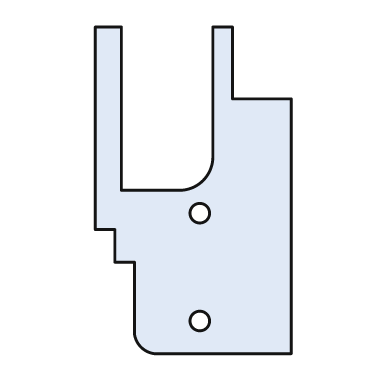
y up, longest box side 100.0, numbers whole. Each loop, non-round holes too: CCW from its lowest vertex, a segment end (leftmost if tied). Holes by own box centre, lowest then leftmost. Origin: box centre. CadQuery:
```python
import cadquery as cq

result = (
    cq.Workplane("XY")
    .moveTo(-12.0, -50.0)
    .lineTo(30.0, -50.0)
    .lineTo(30.0, 28.0)
    .lineTo(12.0, 28.0)
    .lineTo(12.0, 50.0)
    .lineTo(6.0, 50.0)
    .lineTo(6.0, 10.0)
    .threePointArc((3.0, 3.0), (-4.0, 0.0))
    .lineTo(-22.0, 0.0)
    .lineTo(-22.0, 50.0)
    .lineTo(-30.0, 50.0)
    .lineTo(-30.0, -12.0)
    .lineTo(-24.0, -12.0)
    .lineTo(-24.0, -22.0)
    .lineTo(-18.0, -22.0)
    .lineTo(-18.0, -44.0)
    .threePointArc((-16.0, -48.0), (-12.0, -50.0))
    .close()
    .moveTo(2.0, -40.0)
    .circle(3.0)
    .moveTo(2.0, -7.0)
    .circle(3.0)
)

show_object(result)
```